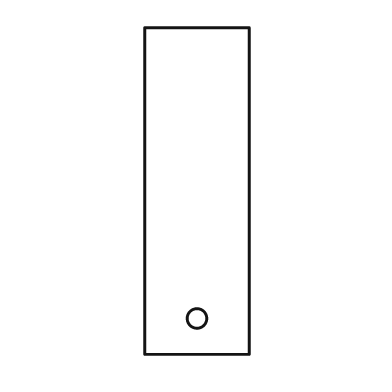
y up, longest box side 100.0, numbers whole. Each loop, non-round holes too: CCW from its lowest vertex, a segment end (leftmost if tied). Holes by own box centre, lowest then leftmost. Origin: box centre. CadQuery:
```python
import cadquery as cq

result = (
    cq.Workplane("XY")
    .moveTo(-16.0, -50.0)
    .lineTo(16.0, -50.0)
    .lineTo(16.0, 50.0)
    .lineTo(-16.0, 50.0)
    .close()
    .moveTo(0.0, -39.0)
    .circle(3.0)
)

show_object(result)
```